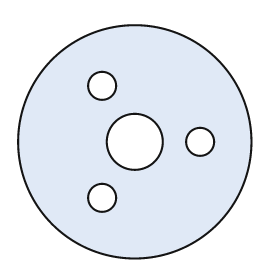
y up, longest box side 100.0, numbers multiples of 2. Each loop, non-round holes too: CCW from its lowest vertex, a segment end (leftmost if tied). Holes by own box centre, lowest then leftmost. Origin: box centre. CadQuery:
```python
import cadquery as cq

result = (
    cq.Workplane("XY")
    .moveTo(0.0, 0.0)
    .circle(50.0)
    .moveTo(-14.0, -24.0)
    .circle(6.0)
    .moveTo(0.0, 0.0)
    .circle(12.0)
    .moveTo(28.0, 0.0)
    .circle(6.0)
    .moveTo(-14.0, 24.0)
    .circle(6.0)
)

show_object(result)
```